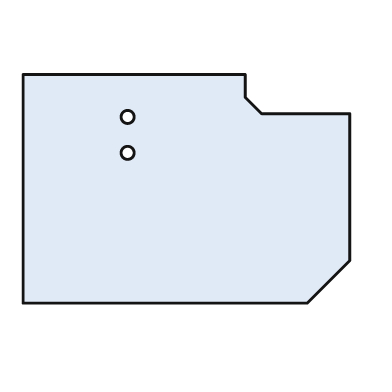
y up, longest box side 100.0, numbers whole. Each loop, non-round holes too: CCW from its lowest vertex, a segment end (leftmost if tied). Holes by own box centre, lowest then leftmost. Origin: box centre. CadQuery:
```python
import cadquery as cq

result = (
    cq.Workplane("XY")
    .moveTo(-50.0, -35.0)
    .lineTo(37.0, -35.0)
    .lineTo(50.0, -22.0)
    .lineTo(50.0, 23.0)
    .lineTo(23.0, 23.0)
    .lineTo(18.0, 28.0)
    .lineTo(18.0, 35.0)
    .lineTo(-50.0, 35.0)
    .close()
    .moveTo(-18.0, 11.0)
    .circle(2.0)
    .moveTo(-18.0, 22.0)
    .circle(2.0)
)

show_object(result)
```